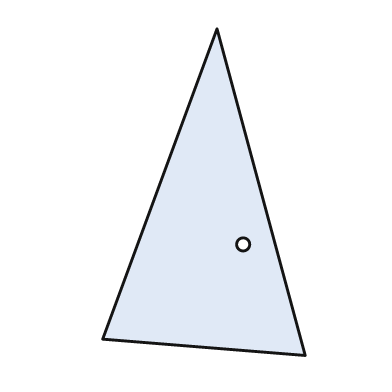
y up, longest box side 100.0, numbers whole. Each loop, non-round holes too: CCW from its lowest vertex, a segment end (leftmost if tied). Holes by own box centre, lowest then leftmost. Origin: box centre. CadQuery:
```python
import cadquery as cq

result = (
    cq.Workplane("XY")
    .moveTo(31.0, -50.0)
    .lineTo(4.0, 50.0)
    .lineTo(-31.0, -45.0)
    .close()
    .moveTo(12.0, -16.0)
    .circle(2.0)
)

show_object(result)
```